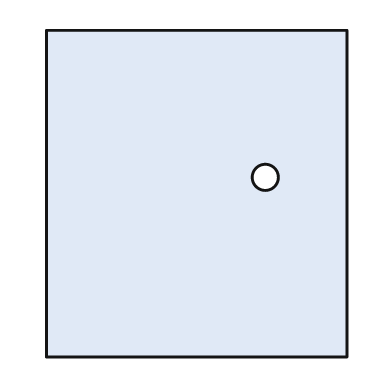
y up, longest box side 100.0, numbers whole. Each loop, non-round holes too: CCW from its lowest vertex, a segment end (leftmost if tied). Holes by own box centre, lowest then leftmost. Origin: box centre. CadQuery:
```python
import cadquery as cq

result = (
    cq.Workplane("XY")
    .moveTo(-46.0, -50.0)
    .lineTo(46.0, -50.0)
    .lineTo(46.0, 50.0)
    .lineTo(-46.0, 50.0)
    .close()
    .moveTo(21.0, 5.0)
    .circle(4.0)
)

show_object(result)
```